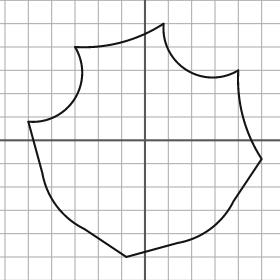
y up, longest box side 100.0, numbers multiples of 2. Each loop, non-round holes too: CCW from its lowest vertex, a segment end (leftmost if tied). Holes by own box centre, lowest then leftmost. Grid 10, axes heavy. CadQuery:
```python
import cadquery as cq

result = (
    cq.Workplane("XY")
    .moveTo(-8.0, -50.0)
    .lineTo(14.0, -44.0)
    .threePointArc((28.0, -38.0), (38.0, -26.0))
    .lineTo(50.0, -8.0)
    .threePointArc((42.0, 10.0), (40.0, 30.0))
    .threePointArc((18.0, 30.0), (8.0, 50.0))
    .threePointArc((-10.0, 42.0), (-30.0, 40.0))
    .threePointArc((-30.0, 18.0), (-50.0, 8.0))
    .lineTo(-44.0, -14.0)
    .threePointArc((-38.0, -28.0), (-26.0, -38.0))
    .close()
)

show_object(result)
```